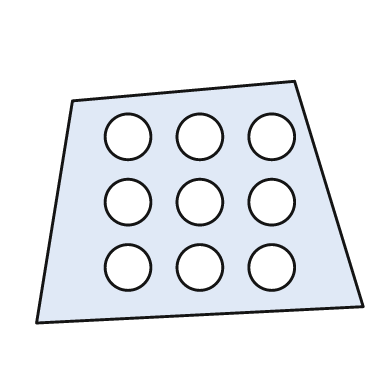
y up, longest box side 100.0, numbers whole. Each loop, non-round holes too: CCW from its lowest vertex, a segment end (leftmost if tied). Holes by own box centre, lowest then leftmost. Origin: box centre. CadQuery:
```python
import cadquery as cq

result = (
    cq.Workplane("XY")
    .moveTo(-50.0, -37.0)
    .lineTo(50.0, -32.0)
    .lineTo(29.0, 37.0)
    .lineTo(-39.0, 31.0)
    .close()
    .moveTo(-22.0, -20.0)
    .circle(7.0)
    .moveTo(0.0, -20.0)
    .circle(7.0)
    .moveTo(22.0, -20.0)
    .circle(7.0)
    .moveTo(-22.0, 0.0)
    .circle(7.0)
    .moveTo(0.0, 0.0)
    .circle(7.0)
    .moveTo(22.0, 0.0)
    .circle(7.0)
    .moveTo(-22.0, 20.0)
    .circle(7.0)
    .moveTo(0.0, 20.0)
    .circle(7.0)
    .moveTo(22.0, 20.0)
    .circle(7.0)
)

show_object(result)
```